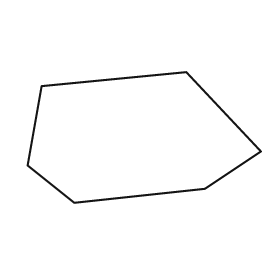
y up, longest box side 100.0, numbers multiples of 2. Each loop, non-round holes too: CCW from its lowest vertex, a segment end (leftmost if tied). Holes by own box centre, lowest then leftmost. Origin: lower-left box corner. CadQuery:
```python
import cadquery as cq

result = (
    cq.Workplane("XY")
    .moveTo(20.0, 0.0)
    .lineTo(76.0, 6.0)
    .lineTo(100.0, 22.0)
    .lineTo(68.0, 56.0)
    .lineTo(6.0, 50.0)
    .lineTo(0.0, 16.0)
    .close()
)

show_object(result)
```